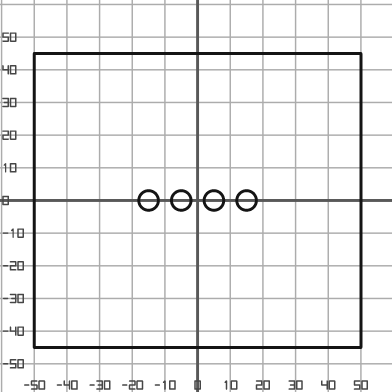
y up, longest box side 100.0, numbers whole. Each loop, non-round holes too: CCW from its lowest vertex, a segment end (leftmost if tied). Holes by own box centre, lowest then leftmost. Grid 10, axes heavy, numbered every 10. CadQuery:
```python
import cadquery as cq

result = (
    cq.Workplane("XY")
    .moveTo(-50.0, -45.0)
    .lineTo(50.0, -45.0)
    .lineTo(50.0, 45.0)
    .lineTo(-50.0, 45.0)
    .close()
    .moveTo(-15.0, 0.0)
    .circle(3.0)
    .moveTo(-5.0, 0.0)
    .circle(3.0)
    .moveTo(5.0, 0.0)
    .circle(3.0)
    .moveTo(15.0, 0.0)
    .circle(3.0)
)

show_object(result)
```